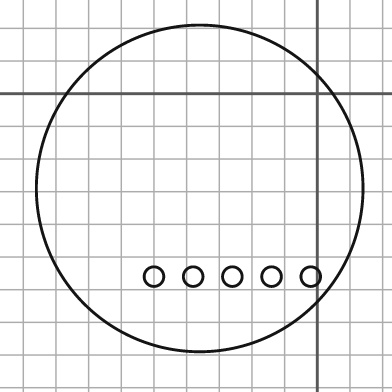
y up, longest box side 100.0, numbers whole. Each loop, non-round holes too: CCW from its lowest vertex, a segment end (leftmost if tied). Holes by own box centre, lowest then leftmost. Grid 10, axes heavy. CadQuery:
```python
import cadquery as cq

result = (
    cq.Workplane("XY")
    .moveTo(-36.0, -29.0)
    .circle(50.0)
    .moveTo(-50.0, -56.0)
    .circle(3.0)
    .moveTo(-38.0, -56.0)
    .circle(3.0)
    .moveTo(-26.0, -56.0)
    .circle(3.0)
    .moveTo(-14.0, -56.0)
    .circle(3.0)
    .moveTo(-2.0, -56.0)
    .circle(3.0)
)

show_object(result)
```